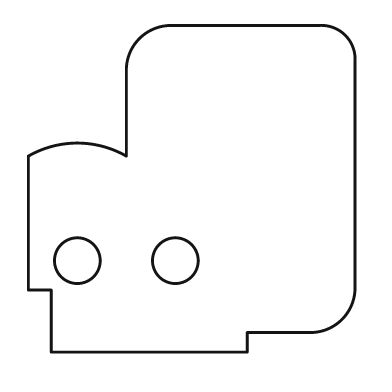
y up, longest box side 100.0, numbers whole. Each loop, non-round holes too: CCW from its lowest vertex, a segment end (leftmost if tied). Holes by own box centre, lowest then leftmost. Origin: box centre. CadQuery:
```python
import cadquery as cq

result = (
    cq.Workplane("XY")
    .moveTo(-43.0, -50.0)
    .lineTo(17.0, -50.0)
    .lineTo(17.0, -44.0)
    .lineTo(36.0, -44.0)
    .threePointArc((46.0, -40.0), (50.0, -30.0))
    .lineTo(50.0, 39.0)
    .threePointArc((47.0, 47.0), (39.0, 50.0))
    .lineTo(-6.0, 50.0)
    .threePointArc((-16.0, 46.0), (-20.0, 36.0))
    .lineTo(-20.0, 10.0)
    .threePointArc((-35.0, 14.0), (-50.0, 10.0))
    .lineTo(-50.0, -31.0)
    .lineTo(-43.0, -31.0)
    .close()
    .moveTo(-35.0, -22.0)
    .circle(7.0)
    .moveTo(-5.0, -22.0)
    .circle(7.0)
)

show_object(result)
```